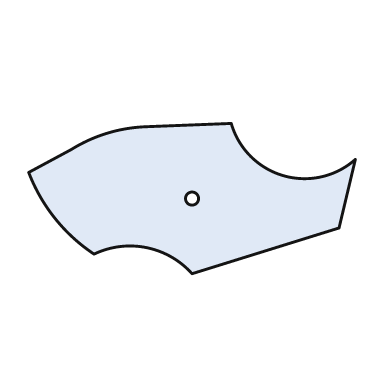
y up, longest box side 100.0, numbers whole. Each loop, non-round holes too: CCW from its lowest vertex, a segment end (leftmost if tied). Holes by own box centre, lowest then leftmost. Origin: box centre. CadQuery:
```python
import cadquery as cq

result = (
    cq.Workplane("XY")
    .moveTo(0.0, -23.0)
    .lineTo(45.0, -9.0)
    .lineTo(50.0, 12.0)
    .threePointArc((28.0, 7.0), (12.0, 23.0))
    .lineTo(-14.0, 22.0)
    .threePointArc((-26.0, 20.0), (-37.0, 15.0))
    .lineTo(-50.0, 8.0)
    .threePointArc((-42.0, -6.0), (-30.0, -17.0))
    .threePointArc((-14.0, -15.0), (0.0, -23.0))
    .close()
    .moveTo(0.0, 0.0)
    .circle(2.0)
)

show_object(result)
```